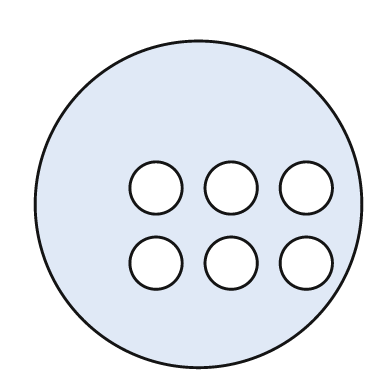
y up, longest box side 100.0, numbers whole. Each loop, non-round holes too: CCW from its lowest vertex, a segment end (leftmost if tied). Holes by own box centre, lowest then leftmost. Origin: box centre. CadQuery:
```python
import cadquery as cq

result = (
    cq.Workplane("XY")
    .moveTo(0.0, 0.0)
    .circle(50.0)
    .moveTo(-13.0, -18.0)
    .circle(8.0)
    .moveTo(10.0, -18.0)
    .circle(8.0)
    .moveTo(33.0, -18.0)
    .circle(8.0)
    .moveTo(-13.0, 5.0)
    .circle(8.0)
    .moveTo(10.0, 5.0)
    .circle(8.0)
    .moveTo(33.0, 5.0)
    .circle(8.0)
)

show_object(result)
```